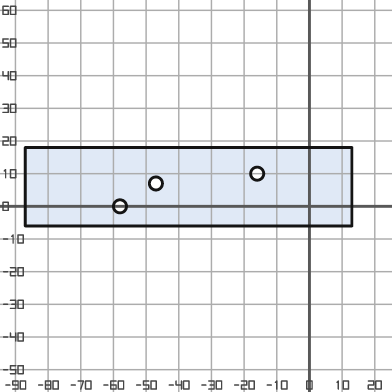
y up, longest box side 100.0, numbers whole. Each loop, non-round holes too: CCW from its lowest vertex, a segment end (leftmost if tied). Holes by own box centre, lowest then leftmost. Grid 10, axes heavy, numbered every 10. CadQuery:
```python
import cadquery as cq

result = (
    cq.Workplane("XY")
    .moveTo(-87.0, -6.0)
    .lineTo(13.0, -6.0)
    .lineTo(13.0, 18.0)
    .lineTo(-87.0, 18.0)
    .close()
    .moveTo(-58.0, 0.0)
    .circle(2.0)
    .moveTo(-47.0, 7.0)
    .circle(2.0)
    .moveTo(-16.0, 10.0)
    .circle(2.0)
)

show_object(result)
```